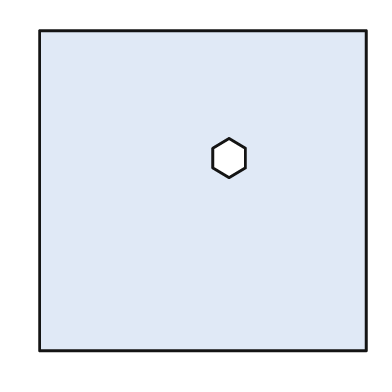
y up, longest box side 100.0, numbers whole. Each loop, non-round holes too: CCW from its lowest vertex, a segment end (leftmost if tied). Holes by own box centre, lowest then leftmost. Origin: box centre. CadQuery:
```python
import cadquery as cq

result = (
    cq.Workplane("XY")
    .moveTo(-50.0, -49.0)
    .lineTo(50.0, -49.0)
    .lineTo(50.0, 49.0)
    .lineTo(-50.0, 49.0)
    .close()
    .moveTo(8.0, 4.0)
    .lineTo(13.0, 7.0)
    .lineTo(13.0, 13.0)
    .lineTo(8.0, 16.0)
    .lineTo(3.0, 13.0)
    .lineTo(3.0, 7.0)
    .close()
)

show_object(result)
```